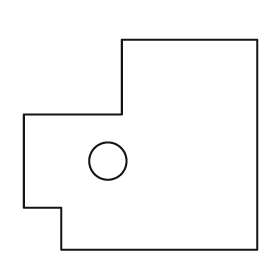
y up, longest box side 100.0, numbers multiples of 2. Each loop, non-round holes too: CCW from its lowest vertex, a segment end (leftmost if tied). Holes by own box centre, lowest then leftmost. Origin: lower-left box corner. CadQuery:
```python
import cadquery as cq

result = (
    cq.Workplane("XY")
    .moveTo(16.0, 0.0)
    .lineTo(100.0, 0.0)
    .lineTo(100.0, 90.0)
    .lineTo(42.0, 90.0)
    .lineTo(42.0, 58.0)
    .lineTo(0.0, 58.0)
    .lineTo(0.0, 18.0)
    .lineTo(16.0, 18.0)
    .close()
    .moveTo(36.0, 38.0)
    .circle(8.0)
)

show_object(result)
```